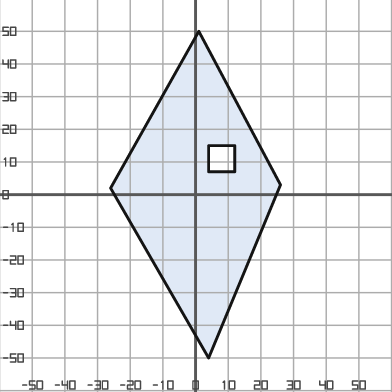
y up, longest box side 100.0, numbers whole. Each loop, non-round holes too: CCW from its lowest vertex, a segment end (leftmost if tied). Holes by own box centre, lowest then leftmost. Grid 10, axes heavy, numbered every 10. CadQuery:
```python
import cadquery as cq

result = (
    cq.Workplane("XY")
    .moveTo(4.0, -50.0)
    .lineTo(26.0, 3.0)
    .lineTo(1.0, 50.0)
    .lineTo(-26.0, 2.0)
    .close()
    .moveTo(4.0, 7.0)
    .lineTo(12.0, 7.0)
    .lineTo(12.0, 15.0)
    .lineTo(4.0, 15.0)
    .close()
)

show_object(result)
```